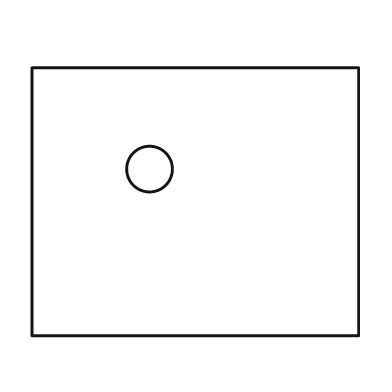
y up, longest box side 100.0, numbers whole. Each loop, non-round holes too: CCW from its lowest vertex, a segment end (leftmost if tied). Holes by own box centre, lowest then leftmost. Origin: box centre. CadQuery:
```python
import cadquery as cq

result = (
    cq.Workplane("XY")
    .moveTo(-50.0, -41.0)
    .lineTo(50.0, -41.0)
    .lineTo(50.0, 41.0)
    .lineTo(-50.0, 41.0)
    .close()
    .moveTo(-14.0, 10.0)
    .circle(7.0)
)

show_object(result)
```